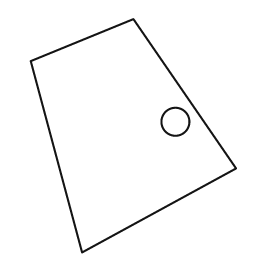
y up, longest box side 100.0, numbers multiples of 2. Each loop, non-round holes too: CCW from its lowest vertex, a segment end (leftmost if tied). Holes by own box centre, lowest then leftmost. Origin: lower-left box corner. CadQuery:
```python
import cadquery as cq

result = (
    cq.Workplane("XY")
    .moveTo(22.0, 0.0)
    .lineTo(88.0, 36.0)
    .lineTo(44.0, 100.0)
    .lineTo(0.0, 82.0)
    .close()
    .moveTo(62.0, 56.0)
    .circle(6.0)
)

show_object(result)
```